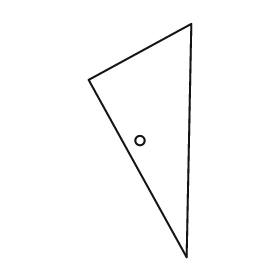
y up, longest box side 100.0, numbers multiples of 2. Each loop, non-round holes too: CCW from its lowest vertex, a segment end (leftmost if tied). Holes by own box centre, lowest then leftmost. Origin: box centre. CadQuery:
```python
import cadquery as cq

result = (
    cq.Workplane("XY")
    .moveTo(20.0, -50.0)
    .lineTo(22.0, 50.0)
    .lineTo(-22.0, 26.0)
    .close()
    .moveTo(0.0, 0.0)
    .circle(2.0)
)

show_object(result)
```